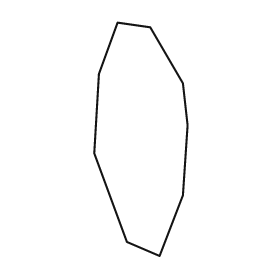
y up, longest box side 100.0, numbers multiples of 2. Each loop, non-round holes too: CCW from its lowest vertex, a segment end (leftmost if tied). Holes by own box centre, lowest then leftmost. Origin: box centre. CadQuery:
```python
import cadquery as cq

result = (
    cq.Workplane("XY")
    .moveTo(8.0, -50.0)
    .lineTo(18.0, -24.0)
    .lineTo(20.0, 6.0)
    .lineTo(18.0, 24.0)
    .lineTo(4.0, 48.0)
    .lineTo(-10.0, 50.0)
    .lineTo(-18.0, 28.0)
    .lineTo(-20.0, -6.0)
    .lineTo(-6.0, -44.0)
    .close()
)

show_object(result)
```